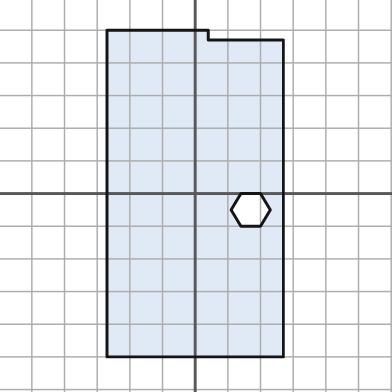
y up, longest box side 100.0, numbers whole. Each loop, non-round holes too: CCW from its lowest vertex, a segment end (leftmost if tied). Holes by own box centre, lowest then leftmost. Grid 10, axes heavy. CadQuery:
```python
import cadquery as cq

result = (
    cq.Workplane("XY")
    .moveTo(-27.0, -50.0)
    .lineTo(27.0, -50.0)
    .lineTo(27.0, 47.0)
    .lineTo(4.0, 47.0)
    .lineTo(4.0, 50.0)
    .lineTo(-27.0, 50.0)
    .close()
    .moveTo(14.0, -10.0)
    .lineTo(20.0, -10.0)
    .lineTo(23.0, -5.0)
    .lineTo(20.0, 0.0)
    .lineTo(14.0, 0.0)
    .lineTo(11.0, -5.0)
    .close()
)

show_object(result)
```